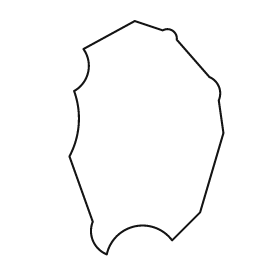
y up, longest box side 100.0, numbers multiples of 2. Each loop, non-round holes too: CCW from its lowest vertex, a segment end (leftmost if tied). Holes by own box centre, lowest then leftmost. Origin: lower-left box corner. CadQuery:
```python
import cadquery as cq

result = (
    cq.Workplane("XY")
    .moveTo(16.0, 0.0)
    .threePointArc((28.0, 12.0), (44.0, 6.0))
    .lineTo(56.0, 18.0)
    .lineTo(66.0, 52.0)
    .lineTo(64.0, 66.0)
    .threePointArc((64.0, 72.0), (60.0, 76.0))
    .lineTo(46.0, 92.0)
    .threePointArc((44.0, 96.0), (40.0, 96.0))
    .lineTo(28.0, 100.0)
    .lineTo(6.0, 88.0)
    .threePointArc((8.0, 78.0), (2.0, 70.0))
    .threePointArc((4.0, 56.0), (0.0, 42.0))
    .lineTo(10.0, 14.0)
    .threePointArc((10.0, 6.0), (16.0, 0.0))
    .close()
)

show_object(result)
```